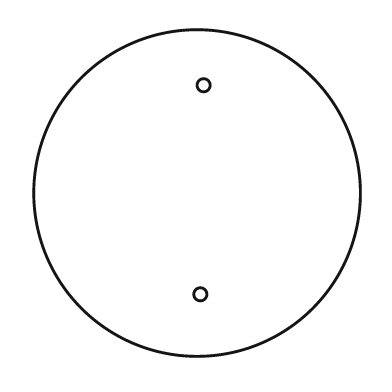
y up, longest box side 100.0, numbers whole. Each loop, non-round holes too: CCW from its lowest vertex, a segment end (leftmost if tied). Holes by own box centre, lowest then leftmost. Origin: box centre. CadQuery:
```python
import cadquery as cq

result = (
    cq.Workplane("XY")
    .moveTo(0.0, 0.0)
    .circle(50.0)
    .moveTo(1.0, -31.0)
    .circle(2.0)
    .moveTo(2.0, 33.0)
    .circle(2.0)
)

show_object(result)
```